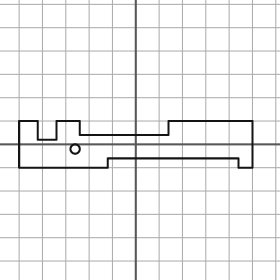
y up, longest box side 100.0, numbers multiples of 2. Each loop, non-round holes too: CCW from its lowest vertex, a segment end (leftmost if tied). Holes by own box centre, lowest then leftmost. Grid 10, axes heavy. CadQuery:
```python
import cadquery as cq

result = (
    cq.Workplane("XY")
    .moveTo(-50.0, -10.0)
    .lineTo(-12.0, -10.0)
    .lineTo(-12.0, -6.0)
    .lineTo(44.0, -6.0)
    .lineTo(44.0, -10.0)
    .lineTo(50.0, -10.0)
    .lineTo(50.0, 10.0)
    .lineTo(14.0, 10.0)
    .lineTo(14.0, 4.0)
    .lineTo(-24.0, 4.0)
    .lineTo(-24.0, 10.0)
    .lineTo(-34.0, 10.0)
    .lineTo(-34.0, 2.0)
    .lineTo(-42.0, 2.0)
    .lineTo(-42.0, 10.0)
    .lineTo(-50.0, 10.0)
    .close()
    .moveTo(-26.0, -2.0)
    .circle(2.0)
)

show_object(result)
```